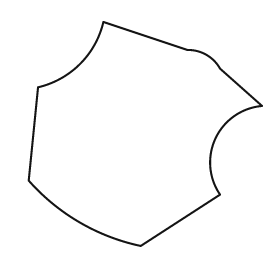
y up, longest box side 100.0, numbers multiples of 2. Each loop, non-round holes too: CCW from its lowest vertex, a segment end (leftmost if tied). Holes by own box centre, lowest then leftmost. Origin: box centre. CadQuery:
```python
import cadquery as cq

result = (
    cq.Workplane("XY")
    .moveTo(-2.0, -48.0)
    .lineTo(32.0, -26.0)
    .threePointArc((30.0, -2.0), (50.0, 12.0))
    .lineTo(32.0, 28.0)
    .threePointArc((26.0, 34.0), (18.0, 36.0))
    .lineTo(-18.0, 48.0)
    .threePointArc((-28.0, 30.0), (-46.0, 20.0))
    .lineTo(-50.0, -20.0)
    .threePointArc((-28.0, -38.0), (-2.0, -48.0))
    .close()
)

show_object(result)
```